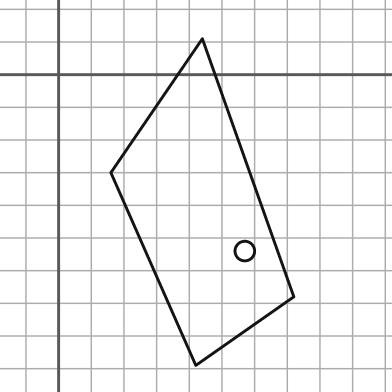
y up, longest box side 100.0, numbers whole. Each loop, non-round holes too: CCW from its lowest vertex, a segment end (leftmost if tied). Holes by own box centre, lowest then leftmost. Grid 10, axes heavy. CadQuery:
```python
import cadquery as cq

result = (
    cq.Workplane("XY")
    .moveTo(42.0, -89.0)
    .lineTo(72.0, -68.0)
    .lineTo(44.0, 11.0)
    .lineTo(16.0, -30.0)
    .close()
    .moveTo(57.0, -54.0)
    .circle(3.0)
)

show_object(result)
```